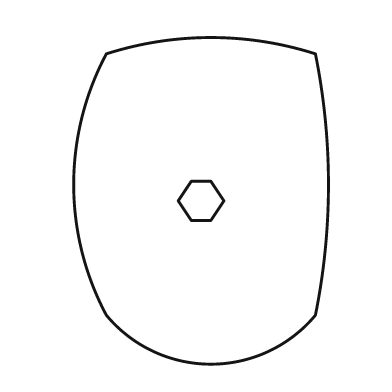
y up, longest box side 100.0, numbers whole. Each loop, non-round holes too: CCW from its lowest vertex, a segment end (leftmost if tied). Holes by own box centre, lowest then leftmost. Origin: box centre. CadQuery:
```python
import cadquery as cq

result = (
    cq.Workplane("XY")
    .moveTo(-29.0, -35.0)
    .threePointArc((3.0, -50.0), (35.0, -35.0))
    .threePointArc((39.0, 5.0), (35.0, 45.0))
    .threePointArc((3.0, 50.0), (-29.0, 45.0))
    .threePointArc((-39.0, 5.0), (-29.0, -35.0))
    .close()
    .moveTo(-3.0, -6.0)
    .lineTo(3.0, -6.0)
    .lineTo(7.0, 0.0)
    .lineTo(3.0, 6.0)
    .lineTo(-3.0, 6.0)
    .lineTo(-7.0, 0.0)
    .close()
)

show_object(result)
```